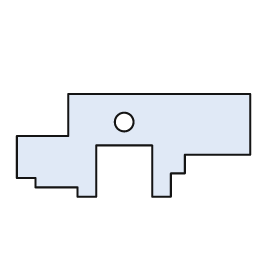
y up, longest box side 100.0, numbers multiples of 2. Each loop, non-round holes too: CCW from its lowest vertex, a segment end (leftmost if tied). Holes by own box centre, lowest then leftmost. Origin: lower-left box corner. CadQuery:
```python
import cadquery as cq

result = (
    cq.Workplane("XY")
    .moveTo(26.0, 0.0)
    .lineTo(34.0, 0.0)
    .lineTo(34.0, 22.0)
    .lineTo(58.0, 22.0)
    .lineTo(58.0, 0.0)
    .lineTo(66.0, 0.0)
    .lineTo(66.0, 10.0)
    .lineTo(72.0, 10.0)
    .lineTo(72.0, 18.0)
    .lineTo(100.0, 18.0)
    .lineTo(100.0, 44.0)
    .lineTo(22.0, 44.0)
    .lineTo(22.0, 26.0)
    .lineTo(0.0, 26.0)
    .lineTo(0.0, 8.0)
    .lineTo(8.0, 8.0)
    .lineTo(8.0, 4.0)
    .lineTo(26.0, 4.0)
    .close()
    .moveTo(46.0, 32.0)
    .circle(4.0)
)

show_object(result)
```